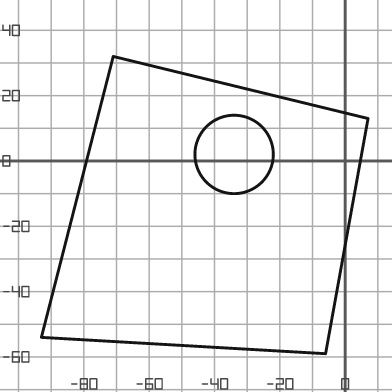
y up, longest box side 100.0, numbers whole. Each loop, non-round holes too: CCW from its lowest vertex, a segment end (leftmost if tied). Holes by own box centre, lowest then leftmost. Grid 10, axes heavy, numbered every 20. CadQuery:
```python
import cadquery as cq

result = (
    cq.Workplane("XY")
    .moveTo(-6.0, -59.0)
    .lineTo(7.0, 13.0)
    .lineTo(-71.0, 32.0)
    .lineTo(-93.0, -54.0)
    .close()
    .moveTo(-34.0, 2.0)
    .circle(12.0)
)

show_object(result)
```